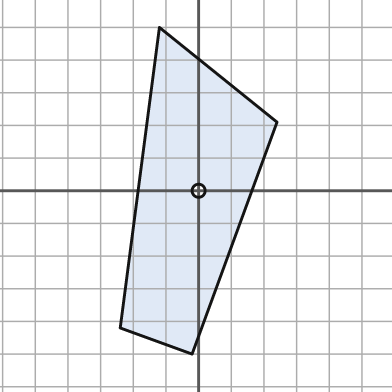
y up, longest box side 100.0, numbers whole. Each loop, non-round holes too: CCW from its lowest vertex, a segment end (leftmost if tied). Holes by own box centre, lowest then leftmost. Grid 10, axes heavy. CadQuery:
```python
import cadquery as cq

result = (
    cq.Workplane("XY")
    .moveTo(-2.0, -50.0)
    .lineTo(24.0, 21.0)
    .lineTo(-12.0, 50.0)
    .lineTo(-24.0, -42.0)
    .close()
    .moveTo(0.0, 0.0)
    .circle(2.0)
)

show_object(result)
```